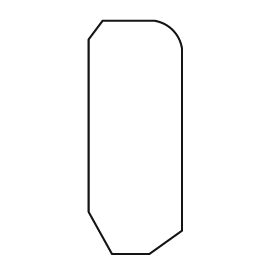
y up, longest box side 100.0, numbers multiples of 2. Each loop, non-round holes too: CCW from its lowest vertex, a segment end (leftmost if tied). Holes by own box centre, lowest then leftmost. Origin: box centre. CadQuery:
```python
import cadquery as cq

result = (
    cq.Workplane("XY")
    .moveTo(-10.0, -50.0)
    .lineTo(6.0, -50.0)
    .lineTo(20.0, -40.0)
    .lineTo(20.0, 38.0)
    .threePointArc((16.0, 46.0), (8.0, 50.0))
    .lineTo(-14.0, 50.0)
    .lineTo(-20.0, 42.0)
    .lineTo(-20.0, -32.0)
    .close()
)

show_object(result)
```